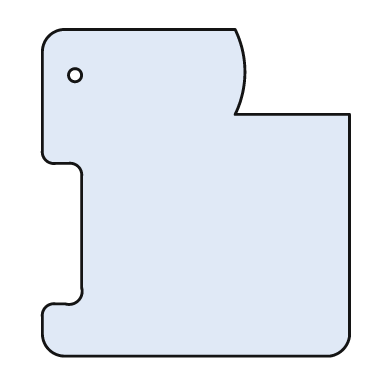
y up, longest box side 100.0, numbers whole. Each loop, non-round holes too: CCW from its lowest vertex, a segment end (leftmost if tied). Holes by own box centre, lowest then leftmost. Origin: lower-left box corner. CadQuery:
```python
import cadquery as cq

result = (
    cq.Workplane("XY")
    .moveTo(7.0, 0.0)
    .lineTo(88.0, 0.0)
    .threePointArc((92.0, 2.0), (94.0, 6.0))
    .lineTo(94.0, 74.0)
    .lineTo(59.0, 74.0)
    .threePointArc((62.0, 87.0), (59.0, 100.0))
    .lineTo(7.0, 100.0)
    .threePointArc((2.0, 98.0), (0.0, 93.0))
    .lineTo(0.0, 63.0)
    .threePointArc((1.0, 60.0), (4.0, 59.0))
    .lineTo(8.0, 59.0)
    .threePointArc((11.0, 58.0), (12.0, 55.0))
    .lineTo(12.0, 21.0)
    .threePointArc((11.0, 17.0), (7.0, 16.0))
    .lineTo(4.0, 16.0)
    .threePointArc((1.0, 15.0), (0.0, 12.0))
    .lineTo(0.0, 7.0)
    .threePointArc((2.0, 2.0), (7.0, 0.0))
    .close()
    .moveTo(10.0, 86.0)
    .circle(2.0)
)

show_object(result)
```